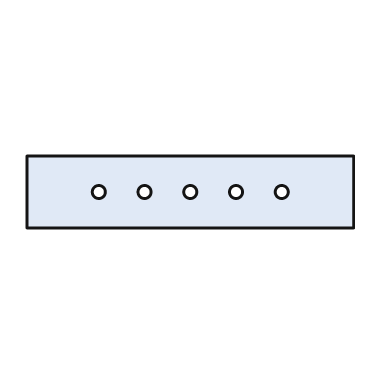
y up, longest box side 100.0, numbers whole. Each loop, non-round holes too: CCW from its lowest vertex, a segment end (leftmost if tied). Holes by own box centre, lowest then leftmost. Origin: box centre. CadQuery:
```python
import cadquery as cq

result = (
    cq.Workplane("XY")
    .moveTo(-50.0, -11.0)
    .lineTo(50.0, -11.0)
    .lineTo(50.0, 11.0)
    .lineTo(-50.0, 11.0)
    .close()
    .moveTo(-28.0, 0.0)
    .circle(2.0)
    .moveTo(-14.0, 0.0)
    .circle(2.0)
    .moveTo(0.0, 0.0)
    .circle(2.0)
    .moveTo(14.0, 0.0)
    .circle(2.0)
    .moveTo(28.0, 0.0)
    .circle(2.0)
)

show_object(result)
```